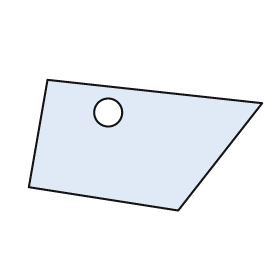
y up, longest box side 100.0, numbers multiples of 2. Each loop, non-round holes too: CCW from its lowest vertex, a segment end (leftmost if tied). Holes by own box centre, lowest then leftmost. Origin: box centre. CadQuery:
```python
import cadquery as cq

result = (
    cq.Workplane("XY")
    .moveTo(14.0, -28.0)
    .lineTo(50.0, 18.0)
    .lineTo(-42.0, 28.0)
    .lineTo(-50.0, -18.0)
    .close()
    .moveTo(-16.0, 14.0)
    .circle(6.0)
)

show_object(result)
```